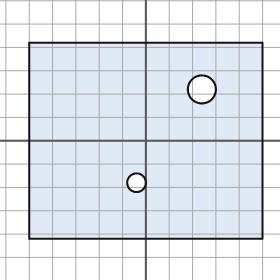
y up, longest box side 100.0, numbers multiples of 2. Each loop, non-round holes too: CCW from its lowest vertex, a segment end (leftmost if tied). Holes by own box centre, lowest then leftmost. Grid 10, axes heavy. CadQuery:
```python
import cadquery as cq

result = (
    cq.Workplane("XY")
    .moveTo(-50.0, -42.0)
    .lineTo(50.0, -42.0)
    .lineTo(50.0, 42.0)
    .lineTo(-50.0, 42.0)
    .close()
    .moveTo(-4.0, -18.0)
    .circle(4.0)
    .moveTo(24.0, 22.0)
    .circle(6.0)
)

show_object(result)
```